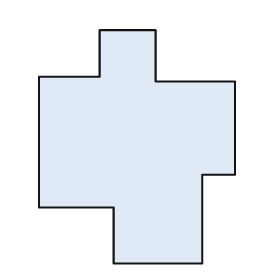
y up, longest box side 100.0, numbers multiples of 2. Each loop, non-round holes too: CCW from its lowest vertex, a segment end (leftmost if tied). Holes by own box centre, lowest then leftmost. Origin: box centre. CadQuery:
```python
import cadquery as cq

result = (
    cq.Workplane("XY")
    .moveTo(-10.0, -50.0)
    .lineTo(28.0, -50.0)
    .lineTo(28.0, -12.0)
    .lineTo(42.0, -12.0)
    .lineTo(42.0, 28.0)
    .lineTo(8.0, 28.0)
    .lineTo(8.0, 50.0)
    .lineTo(-16.0, 50.0)
    .lineTo(-16.0, 30.0)
    .lineTo(-42.0, 30.0)
    .lineTo(-42.0, -26.0)
    .lineTo(-10.0, -26.0)
    .close()
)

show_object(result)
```